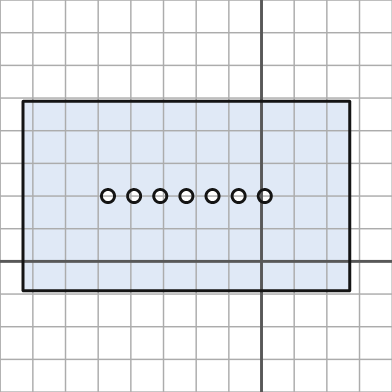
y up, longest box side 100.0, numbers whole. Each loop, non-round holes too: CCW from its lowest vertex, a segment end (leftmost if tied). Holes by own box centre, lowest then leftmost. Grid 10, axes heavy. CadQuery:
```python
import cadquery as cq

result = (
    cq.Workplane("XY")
    .moveTo(-73.0, -9.0)
    .lineTo(27.0, -9.0)
    .lineTo(27.0, 49.0)
    .lineTo(-73.0, 49.0)
    .close()
    .moveTo(-47.0, 20.0)
    .circle(2.0)
    .moveTo(-39.0, 20.0)
    .circle(2.0)
    .moveTo(-31.0, 20.0)
    .circle(2.0)
    .moveTo(-23.0, 20.0)
    .circle(2.0)
    .moveTo(-15.0, 20.0)
    .circle(2.0)
    .moveTo(-7.0, 20.0)
    .circle(2.0)
    .moveTo(1.0, 20.0)
    .circle(2.0)
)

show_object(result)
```